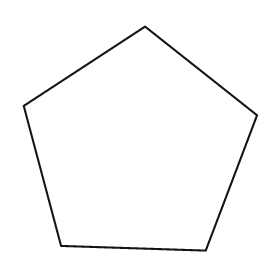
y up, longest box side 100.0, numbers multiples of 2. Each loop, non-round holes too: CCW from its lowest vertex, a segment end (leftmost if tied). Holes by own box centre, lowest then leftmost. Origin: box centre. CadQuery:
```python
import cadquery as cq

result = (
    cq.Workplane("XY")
    .moveTo(28.0, -48.0)
    .lineTo(50.0, 10.0)
    .lineTo(2.0, 48.0)
    .lineTo(-50.0, 14.0)
    .lineTo(-34.0, -46.0)
    .close()
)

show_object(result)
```